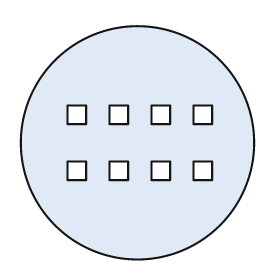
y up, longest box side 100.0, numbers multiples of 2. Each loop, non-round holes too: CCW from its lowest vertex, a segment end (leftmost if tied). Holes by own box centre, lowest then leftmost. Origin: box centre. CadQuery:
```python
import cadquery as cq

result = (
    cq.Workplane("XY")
    .moveTo(0.0, 0.0)
    .circle(50.0)
    .moveTo(-30.0, -16.0)
    .lineTo(-22.0, -16.0)
    .lineTo(-22.0, -8.0)
    .lineTo(-30.0, -8.0)
    .close()
    .moveTo(-12.0, -16.0)
    .lineTo(-4.0, -16.0)
    .lineTo(-4.0, -8.0)
    .lineTo(-12.0, -8.0)
    .close()
    .moveTo(6.0, -16.0)
    .lineTo(14.0, -16.0)
    .lineTo(14.0, -8.0)
    .lineTo(6.0, -8.0)
    .close()
    .moveTo(24.0, -16.0)
    .lineTo(32.0, -16.0)
    .lineTo(32.0, -8.0)
    .lineTo(24.0, -8.0)
    .close()
    .moveTo(-30.0, 8.0)
    .lineTo(-22.0, 8.0)
    .lineTo(-22.0, 16.0)
    .lineTo(-30.0, 16.0)
    .close()
    .moveTo(-12.0, 8.0)
    .lineTo(-4.0, 8.0)
    .lineTo(-4.0, 16.0)
    .lineTo(-12.0, 16.0)
    .close()
    .moveTo(6.0, 8.0)
    .lineTo(14.0, 8.0)
    .lineTo(14.0, 16.0)
    .lineTo(6.0, 16.0)
    .close()
    .moveTo(24.0, 8.0)
    .lineTo(32.0, 8.0)
    .lineTo(32.0, 16.0)
    .lineTo(24.0, 16.0)
    .close()
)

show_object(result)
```